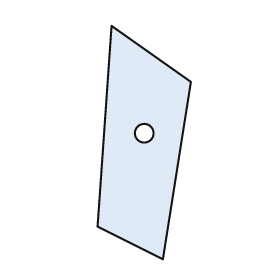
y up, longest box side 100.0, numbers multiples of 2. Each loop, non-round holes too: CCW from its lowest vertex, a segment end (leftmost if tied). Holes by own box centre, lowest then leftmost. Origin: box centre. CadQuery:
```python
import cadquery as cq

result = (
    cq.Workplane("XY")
    .moveTo(8.0, -50.0)
    .lineTo(20.0, 26.0)
    .lineTo(-14.0, 50.0)
    .lineTo(-20.0, -36.0)
    .close()
    .moveTo(0.0, 4.0)
    .circle(4.0)
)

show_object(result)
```